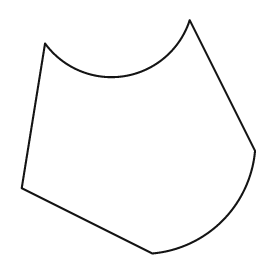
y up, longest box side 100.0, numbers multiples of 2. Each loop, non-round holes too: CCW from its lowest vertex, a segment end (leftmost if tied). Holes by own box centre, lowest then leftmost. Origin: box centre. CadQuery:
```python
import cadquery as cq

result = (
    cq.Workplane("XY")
    .moveTo(6.0, -50.0)
    .threePointArc((36.0, -36.0), (50.0, -6.0))
    .lineTo(22.0, 50.0)
    .threePointArc((-6.0, 26.0), (-40.0, 40.0))
    .lineTo(-50.0, -22.0)
    .close()
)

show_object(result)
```